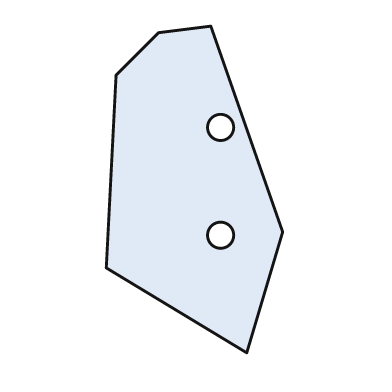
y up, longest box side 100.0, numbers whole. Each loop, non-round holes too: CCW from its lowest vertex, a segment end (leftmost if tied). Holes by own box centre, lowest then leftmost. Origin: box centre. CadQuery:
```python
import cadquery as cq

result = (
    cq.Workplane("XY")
    .moveTo(16.0, -50.0)
    .lineTo(27.0, -13.0)
    .lineTo(5.0, 50.0)
    .lineTo(-11.0, 48.0)
    .lineTo(-24.0, 35.0)
    .lineTo(-27.0, -24.0)
    .close()
    .moveTo(8.0, -14.0)
    .circle(4.0)
    .moveTo(8.0, 19.0)
    .circle(4.0)
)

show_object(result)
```